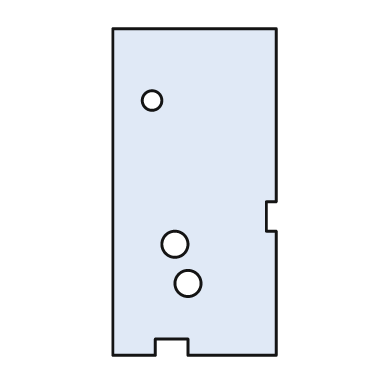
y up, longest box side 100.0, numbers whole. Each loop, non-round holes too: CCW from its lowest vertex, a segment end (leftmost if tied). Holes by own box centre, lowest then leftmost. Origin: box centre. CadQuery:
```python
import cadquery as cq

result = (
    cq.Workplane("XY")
    .moveTo(-25.0, -50.0)
    .lineTo(-12.0, -50.0)
    .lineTo(-12.0, -45.0)
    .lineTo(-2.0, -45.0)
    .lineTo(-2.0, -50.0)
    .lineTo(25.0, -50.0)
    .lineTo(25.0, -12.0)
    .lineTo(22.0, -12.0)
    .lineTo(22.0, -3.0)
    .lineTo(25.0, -3.0)
    .lineTo(25.0, 50.0)
    .lineTo(-25.0, 50.0)
    .close()
    .moveTo(-2.0, -28.0)
    .circle(4.0)
    .moveTo(-6.0, -16.0)
    .circle(4.0)
    .moveTo(-13.0, 28.0)
    .circle(3.0)
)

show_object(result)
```